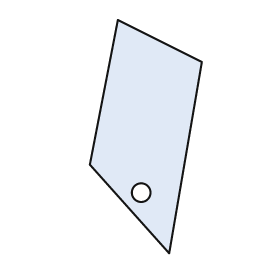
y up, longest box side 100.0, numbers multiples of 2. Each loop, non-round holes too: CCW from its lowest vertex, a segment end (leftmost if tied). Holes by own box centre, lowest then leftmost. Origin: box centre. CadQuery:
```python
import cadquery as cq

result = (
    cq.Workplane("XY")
    .moveTo(10.0, -50.0)
    .lineTo(24.0, 32.0)
    .lineTo(-12.0, 50.0)
    .lineTo(-24.0, -12.0)
    .close()
    .moveTo(-2.0, -24.0)
    .circle(4.0)
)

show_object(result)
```